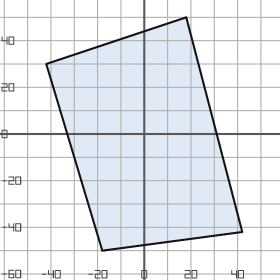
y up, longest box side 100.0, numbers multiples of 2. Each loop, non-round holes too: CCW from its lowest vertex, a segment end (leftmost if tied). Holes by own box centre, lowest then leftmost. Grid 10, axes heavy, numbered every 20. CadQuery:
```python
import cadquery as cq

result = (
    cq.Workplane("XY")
    .moveTo(-18.0, -50.0)
    .lineTo(42.0, -42.0)
    .lineTo(18.0, 50.0)
    .lineTo(-42.0, 30.0)
    .close()
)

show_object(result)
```